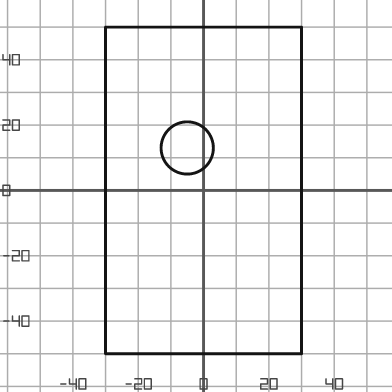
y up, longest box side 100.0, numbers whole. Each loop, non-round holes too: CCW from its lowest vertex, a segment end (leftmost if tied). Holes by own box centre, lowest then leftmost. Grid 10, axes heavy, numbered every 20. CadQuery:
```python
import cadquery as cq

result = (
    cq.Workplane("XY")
    .moveTo(-30.0, -50.0)
    .lineTo(30.0, -50.0)
    .lineTo(30.0, 50.0)
    .lineTo(-30.0, 50.0)
    .close()
    .moveTo(-5.0, 13.0)
    .circle(8.0)
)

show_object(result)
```